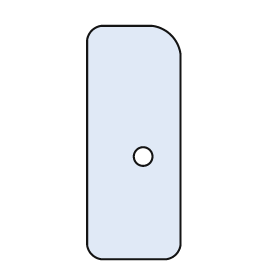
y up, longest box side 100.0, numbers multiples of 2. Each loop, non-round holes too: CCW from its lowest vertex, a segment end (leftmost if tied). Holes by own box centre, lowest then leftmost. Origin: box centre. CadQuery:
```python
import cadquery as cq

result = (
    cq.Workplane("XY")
    .moveTo(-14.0, -50.0)
    .lineTo(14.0, -50.0)
    .threePointArc((18.0, -48.0), (20.0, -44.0))
    .lineTo(20.0, 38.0)
    .threePointArc((16.0, 46.0), (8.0, 50.0))
    .lineTo(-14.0, 50.0)
    .threePointArc((-18.0, 48.0), (-20.0, 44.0))
    .lineTo(-20.0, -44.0)
    .threePointArc((-18.0, -48.0), (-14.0, -50.0))
    .close()
    .moveTo(4.0, -6.0)
    .circle(4.0)
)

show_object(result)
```